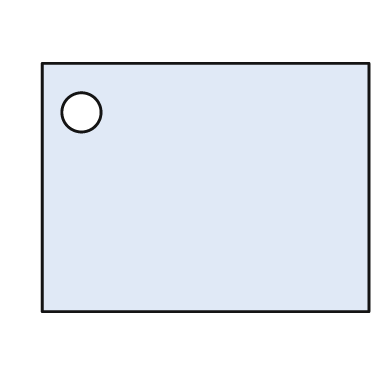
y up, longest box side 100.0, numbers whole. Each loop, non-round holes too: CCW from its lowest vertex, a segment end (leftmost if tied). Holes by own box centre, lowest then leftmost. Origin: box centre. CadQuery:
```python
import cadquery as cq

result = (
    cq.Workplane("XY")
    .moveTo(-50.0, -38.0)
    .lineTo(50.0, -38.0)
    .lineTo(50.0, 38.0)
    .lineTo(-50.0, 38.0)
    .close()
    .moveTo(-38.0, 23.0)
    .circle(6.0)
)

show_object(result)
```